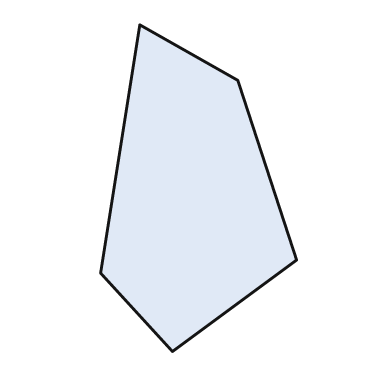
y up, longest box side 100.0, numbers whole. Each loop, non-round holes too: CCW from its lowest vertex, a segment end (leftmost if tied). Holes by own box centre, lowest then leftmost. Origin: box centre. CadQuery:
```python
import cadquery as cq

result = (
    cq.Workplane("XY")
    .moveTo(-8.0, -50.0)
    .lineTo(30.0, -22.0)
    .lineTo(12.0, 33.0)
    .lineTo(-18.0, 50.0)
    .lineTo(-30.0, -26.0)
    .close()
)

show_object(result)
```